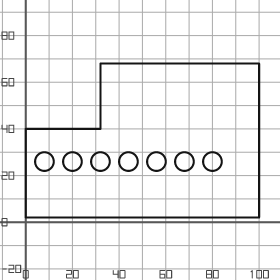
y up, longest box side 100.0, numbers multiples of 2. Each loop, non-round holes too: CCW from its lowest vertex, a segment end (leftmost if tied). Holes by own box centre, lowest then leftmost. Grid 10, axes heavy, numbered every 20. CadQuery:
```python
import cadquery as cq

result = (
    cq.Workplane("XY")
    .moveTo(0.0, 2.0)
    .lineTo(100.0, 2.0)
    .lineTo(100.0, 68.0)
    .lineTo(32.0, 68.0)
    .lineTo(32.0, 40.0)
    .lineTo(0.0, 40.0)
    .close()
    .moveTo(8.0, 26.0)
    .circle(4.0)
    .moveTo(20.0, 26.0)
    .circle(4.0)
    .moveTo(32.0, 26.0)
    .circle(4.0)
    .moveTo(44.0, 26.0)
    .circle(4.0)
    .moveTo(56.0, 26.0)
    .circle(4.0)
    .moveTo(68.0, 26.0)
    .circle(4.0)
    .moveTo(80.0, 26.0)
    .circle(4.0)
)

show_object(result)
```